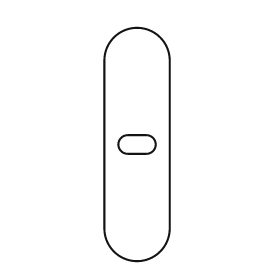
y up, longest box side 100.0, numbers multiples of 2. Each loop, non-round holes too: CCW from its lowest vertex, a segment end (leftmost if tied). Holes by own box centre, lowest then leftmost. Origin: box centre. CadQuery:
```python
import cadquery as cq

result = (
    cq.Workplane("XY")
    .moveTo(-14.0, -36.0)
    .threePointArc((0.0, -50.0), (14.0, -36.0))
    .lineTo(14.0, 36.0)
    .threePointArc((0.0, 50.0), (-14.0, 36.0))
    .close()
    .moveTo(-4.0, -4.0)
    .lineTo(4.0, -4.0)
    .threePointArc((8.0, 0.0), (4.0, 4.0))
    .lineTo(-4.0, 4.0)
    .threePointArc((-8.0, 0.0), (-4.0, -4.0))
    .close()
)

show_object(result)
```